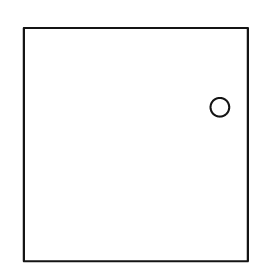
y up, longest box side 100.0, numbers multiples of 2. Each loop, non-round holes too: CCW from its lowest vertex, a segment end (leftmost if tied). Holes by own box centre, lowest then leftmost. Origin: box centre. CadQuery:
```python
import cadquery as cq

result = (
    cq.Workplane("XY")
    .moveTo(-48.0, -50.0)
    .lineTo(48.0, -50.0)
    .lineTo(48.0, 50.0)
    .lineTo(-48.0, 50.0)
    .close()
    .moveTo(36.0, 16.0)
    .circle(4.0)
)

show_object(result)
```